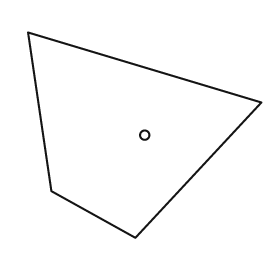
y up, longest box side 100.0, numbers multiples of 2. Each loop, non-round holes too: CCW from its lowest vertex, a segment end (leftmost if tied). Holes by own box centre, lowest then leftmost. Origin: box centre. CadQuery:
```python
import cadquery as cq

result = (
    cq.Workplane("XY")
    .moveTo(-4.0, -44.0)
    .lineTo(50.0, 14.0)
    .lineTo(-50.0, 44.0)
    .lineTo(-40.0, -24.0)
    .close()
    .moveTo(0.0, 0.0)
    .circle(2.0)
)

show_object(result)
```